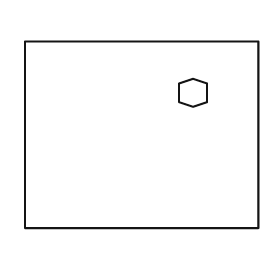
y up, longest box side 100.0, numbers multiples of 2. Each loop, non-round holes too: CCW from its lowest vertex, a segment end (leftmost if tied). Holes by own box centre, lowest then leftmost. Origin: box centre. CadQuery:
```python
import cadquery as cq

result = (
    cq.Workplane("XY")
    .moveTo(-50.0, -40.0)
    .lineTo(50.0, -40.0)
    .lineTo(50.0, 40.0)
    .lineTo(-50.0, 40.0)
    .close()
    .moveTo(22.0, 12.0)
    .lineTo(28.0, 14.0)
    .lineTo(28.0, 22.0)
    .lineTo(22.0, 24.0)
    .lineTo(16.0, 22.0)
    .lineTo(16.0, 14.0)
    .close()
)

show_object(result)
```